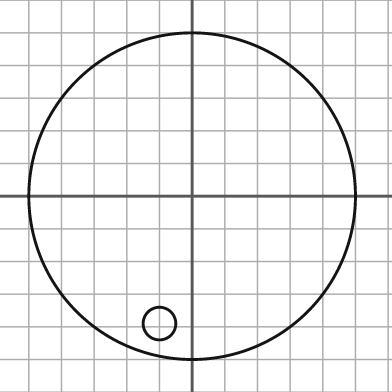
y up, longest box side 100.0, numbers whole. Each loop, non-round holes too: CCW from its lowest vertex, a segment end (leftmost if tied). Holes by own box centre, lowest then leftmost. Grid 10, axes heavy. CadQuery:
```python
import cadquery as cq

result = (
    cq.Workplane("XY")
    .moveTo(0.0, 0.0)
    .circle(50.0)
    .moveTo(-10.0, -39.0)
    .circle(5.0)
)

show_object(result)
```